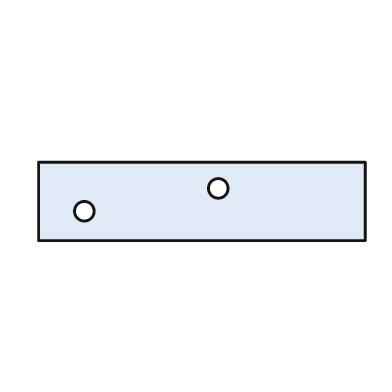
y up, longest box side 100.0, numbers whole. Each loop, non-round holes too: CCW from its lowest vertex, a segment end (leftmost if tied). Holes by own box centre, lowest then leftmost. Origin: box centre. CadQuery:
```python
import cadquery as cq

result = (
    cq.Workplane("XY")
    .moveTo(-50.0, -12.0)
    .lineTo(50.0, -12.0)
    .lineTo(50.0, 12.0)
    .lineTo(-50.0, 12.0)
    .close()
    .moveTo(-36.0, -3.0)
    .circle(3.0)
    .moveTo(5.0, 4.0)
    .circle(3.0)
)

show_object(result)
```